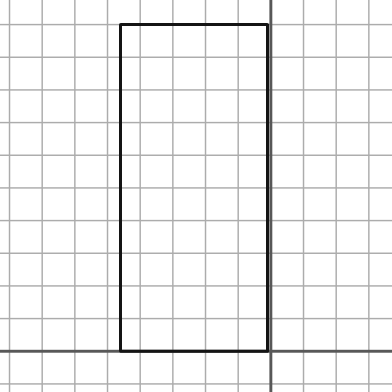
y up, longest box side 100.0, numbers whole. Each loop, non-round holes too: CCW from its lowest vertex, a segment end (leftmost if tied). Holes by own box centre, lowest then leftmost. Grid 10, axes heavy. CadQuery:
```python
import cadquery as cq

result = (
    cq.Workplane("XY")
    .moveTo(-46.0, 0.0)
    .lineTo(-1.0, 0.0)
    .lineTo(-1.0, 100.0)
    .lineTo(-46.0, 100.0)
    .close()
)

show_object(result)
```